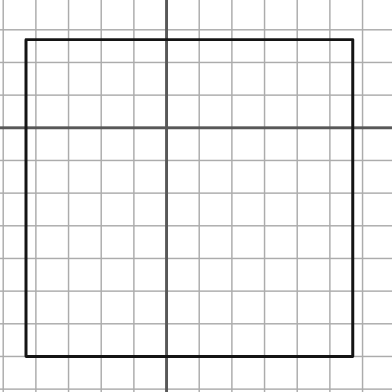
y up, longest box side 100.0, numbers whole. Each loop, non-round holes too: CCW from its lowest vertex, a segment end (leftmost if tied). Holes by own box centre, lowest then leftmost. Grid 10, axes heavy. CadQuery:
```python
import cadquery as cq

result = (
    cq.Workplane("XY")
    .moveTo(-43.0, -70.0)
    .lineTo(57.0, -70.0)
    .lineTo(57.0, 27.0)
    .lineTo(-43.0, 27.0)
    .close()
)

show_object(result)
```